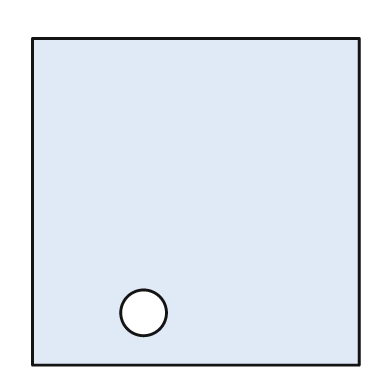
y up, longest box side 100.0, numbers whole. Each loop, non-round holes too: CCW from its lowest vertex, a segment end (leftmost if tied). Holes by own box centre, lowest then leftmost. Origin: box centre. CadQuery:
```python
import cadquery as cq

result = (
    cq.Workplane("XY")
    .moveTo(-50.0, -50.0)
    .lineTo(50.0, -50.0)
    .lineTo(50.0, 50.0)
    .lineTo(-50.0, 50.0)
    .close()
    .moveTo(-16.0, -34.0)
    .circle(7.0)
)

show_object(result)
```